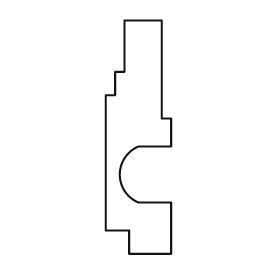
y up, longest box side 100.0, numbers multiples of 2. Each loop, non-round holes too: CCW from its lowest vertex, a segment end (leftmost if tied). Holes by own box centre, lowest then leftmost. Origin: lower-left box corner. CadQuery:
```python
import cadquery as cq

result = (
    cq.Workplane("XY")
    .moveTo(10.0, 0.0)
    .lineTo(28.0, 0.0)
    .lineTo(28.0, 22.0)
    .lineTo(14.0, 22.0)
    .threePointArc((6.0, 34.0), (14.0, 46.0))
    .lineTo(28.0, 46.0)
    .lineTo(28.0, 58.0)
    .lineTo(24.0, 58.0)
    .lineTo(24.0, 100.0)
    .lineTo(8.0, 100.0)
    .lineTo(8.0, 78.0)
    .lineTo(4.0, 78.0)
    .lineTo(4.0, 68.0)
    .lineTo(0.0, 68.0)
    .lineTo(0.0, 10.0)
    .lineTo(10.0, 10.0)
    .close()
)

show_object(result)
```